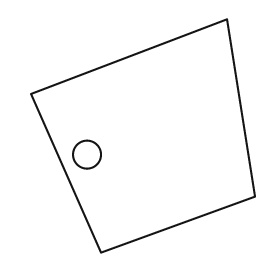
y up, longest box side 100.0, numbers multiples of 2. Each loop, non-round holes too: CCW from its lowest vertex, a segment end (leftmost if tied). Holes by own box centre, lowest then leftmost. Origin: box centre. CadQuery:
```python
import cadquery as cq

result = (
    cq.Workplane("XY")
    .moveTo(-18.0, -50.0)
    .lineTo(48.0, -26.0)
    .lineTo(36.0, 50.0)
    .lineTo(-48.0, 18.0)
    .close()
    .moveTo(-24.0, -8.0)
    .circle(6.0)
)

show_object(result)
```